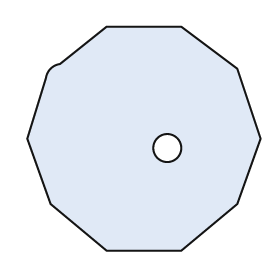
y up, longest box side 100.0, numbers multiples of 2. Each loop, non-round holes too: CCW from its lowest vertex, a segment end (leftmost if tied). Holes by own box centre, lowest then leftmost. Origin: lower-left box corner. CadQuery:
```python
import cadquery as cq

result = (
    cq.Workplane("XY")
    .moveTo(34.0, 0.0)
    .lineTo(66.0, 0.0)
    .lineTo(90.0, 20.0)
    .lineTo(100.0, 48.0)
    .lineTo(90.0, 78.0)
    .lineTo(66.0, 96.0)
    .lineTo(34.0, 96.0)
    .lineTo(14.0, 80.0)
    .threePointArc((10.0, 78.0), (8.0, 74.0))
    .lineTo(0.0, 48.0)
    .lineTo(10.0, 20.0)
    .close()
    .moveTo(60.0, 44.0)
    .circle(6.0)
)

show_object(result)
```